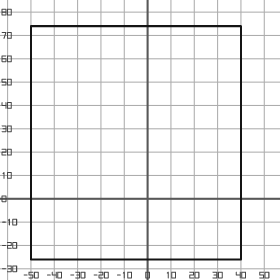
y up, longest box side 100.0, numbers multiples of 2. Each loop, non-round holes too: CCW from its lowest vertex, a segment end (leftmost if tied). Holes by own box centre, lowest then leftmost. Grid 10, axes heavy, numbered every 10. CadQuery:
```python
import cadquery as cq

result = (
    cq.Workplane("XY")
    .moveTo(-50.0, -26.0)
    .lineTo(40.0, -26.0)
    .lineTo(40.0, 74.0)
    .lineTo(-50.0, 74.0)
    .close()
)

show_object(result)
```